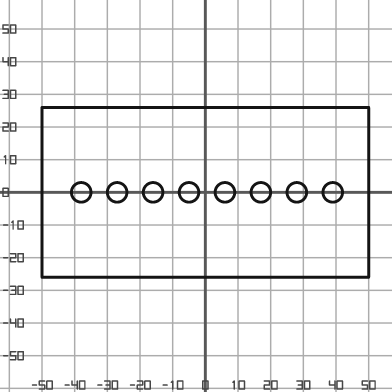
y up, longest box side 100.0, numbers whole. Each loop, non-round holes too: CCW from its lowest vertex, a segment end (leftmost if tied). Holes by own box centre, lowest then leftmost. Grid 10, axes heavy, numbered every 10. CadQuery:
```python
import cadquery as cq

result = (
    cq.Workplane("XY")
    .moveTo(-50.0, -26.0)
    .lineTo(50.0, -26.0)
    .lineTo(50.0, 26.0)
    .lineTo(-50.0, 26.0)
    .close()
    .moveTo(-38.0, 0.0)
    .circle(3.0)
    .moveTo(-27.0, 0.0)
    .circle(3.0)
    .moveTo(-16.0, 0.0)
    .circle(3.0)
    .moveTo(-5.0, 0.0)
    .circle(3.0)
    .moveTo(6.0, 0.0)
    .circle(3.0)
    .moveTo(17.0, 0.0)
    .circle(3.0)
    .moveTo(28.0, 0.0)
    .circle(3.0)
    .moveTo(39.0, 0.0)
    .circle(3.0)
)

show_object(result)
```